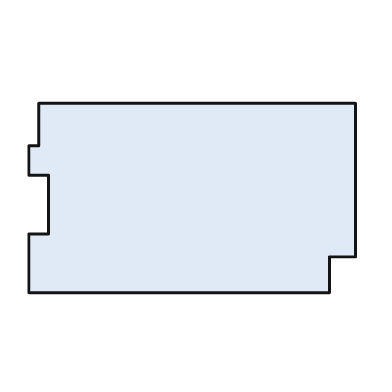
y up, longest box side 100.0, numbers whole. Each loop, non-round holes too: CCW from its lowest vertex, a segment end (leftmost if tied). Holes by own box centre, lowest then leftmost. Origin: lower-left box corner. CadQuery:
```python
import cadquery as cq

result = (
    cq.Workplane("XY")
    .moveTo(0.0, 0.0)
    .lineTo(92.0, 0.0)
    .lineTo(92.0, 11.0)
    .lineTo(100.0, 11.0)
    .lineTo(100.0, 58.0)
    .lineTo(3.0, 58.0)
    .lineTo(3.0, 45.0)
    .lineTo(0.0, 45.0)
    .lineTo(0.0, 36.0)
    .lineTo(6.0, 36.0)
    .lineTo(6.0, 18.0)
    .lineTo(0.0, 18.0)
    .close()
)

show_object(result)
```